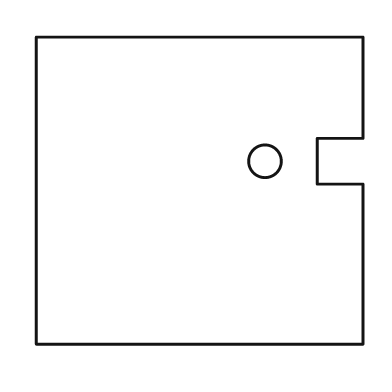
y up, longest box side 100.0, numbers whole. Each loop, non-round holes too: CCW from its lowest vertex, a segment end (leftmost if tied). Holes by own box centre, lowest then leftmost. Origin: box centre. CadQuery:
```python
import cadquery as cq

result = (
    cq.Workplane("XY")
    .moveTo(-50.0, -47.0)
    .lineTo(50.0, -47.0)
    .lineTo(50.0, 2.0)
    .lineTo(36.0, 2.0)
    .lineTo(36.0, 16.0)
    .lineTo(50.0, 16.0)
    .lineTo(50.0, 47.0)
    .lineTo(-50.0, 47.0)
    .close()
    .moveTo(20.0, 9.0)
    .circle(5.0)
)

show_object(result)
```